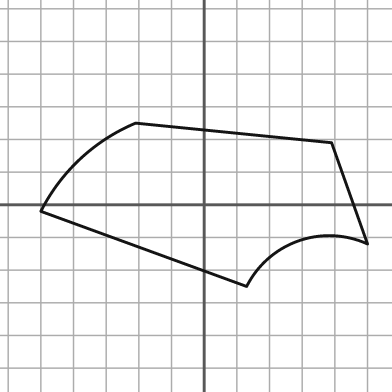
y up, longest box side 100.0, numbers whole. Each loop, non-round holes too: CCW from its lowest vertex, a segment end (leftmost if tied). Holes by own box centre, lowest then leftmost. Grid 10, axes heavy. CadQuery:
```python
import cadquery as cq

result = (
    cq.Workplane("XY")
    .moveTo(13.0, -25.0)
    .threePointArc((29.0, -11.0), (50.0, -12.0))
    .lineTo(39.0, 19.0)
    .lineTo(-21.0, 25.0)
    .threePointArc((-38.0, 14.0), (-50.0, -2.0))
    .close()
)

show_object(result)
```